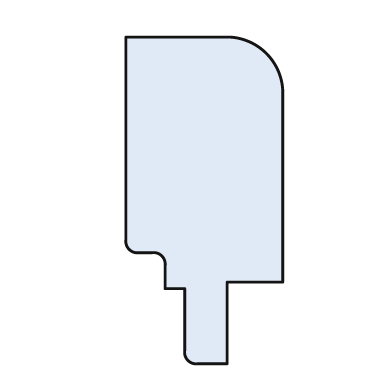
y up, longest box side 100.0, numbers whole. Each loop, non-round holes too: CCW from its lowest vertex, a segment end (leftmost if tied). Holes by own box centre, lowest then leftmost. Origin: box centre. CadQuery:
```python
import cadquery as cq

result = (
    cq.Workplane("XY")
    .moveTo(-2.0, -50.0)
    .lineTo(7.0, -50.0)
    .lineTo(7.0, -25.0)
    .lineTo(24.0, -25.0)
    .lineTo(24.0, 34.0)
    .threePointArc((19.0, 45.0), (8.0, 50.0))
    .lineTo(-24.0, 50.0)
    .lineTo(-24.0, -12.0)
    .threePointArc((-23.0, -15.0), (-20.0, -16.0))
    .lineTo(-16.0, -16.0)
    .threePointArc((-13.0, -17.0), (-12.0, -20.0))
    .lineTo(-12.0, -27.0)
    .lineTo(-6.0, -27.0)
    .lineTo(-6.0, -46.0)
    .threePointArc((-5.0, -49.0), (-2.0, -50.0))
    .close()
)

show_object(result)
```